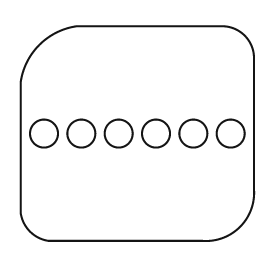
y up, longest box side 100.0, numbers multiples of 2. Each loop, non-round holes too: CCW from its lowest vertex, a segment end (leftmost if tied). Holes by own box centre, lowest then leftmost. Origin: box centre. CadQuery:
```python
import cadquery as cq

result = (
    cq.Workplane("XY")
    .moveTo(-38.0, -46.0)
    .lineTo(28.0, -46.0)
    .threePointArc((44.0, -40.0), (50.0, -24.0))
    .lineTo(50.0, 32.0)
    .threePointArc((46.0, 42.0), (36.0, 46.0))
    .lineTo(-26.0, 46.0)
    .threePointArc((-42.0, 38.0), (-50.0, 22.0))
    .lineTo(-50.0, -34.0)
    .threePointArc((-46.0, -42.0), (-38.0, -46.0))
    .close()
    .moveTo(-40.0, 0.0)
    .circle(6.0)
    .moveTo(-24.0, 0.0)
    .circle(6.0)
    .moveTo(-8.0, 0.0)
    .circle(6.0)
    .moveTo(8.0, 0.0)
    .circle(6.0)
    .moveTo(24.0, 0.0)
    .circle(6.0)
    .moveTo(40.0, 0.0)
    .circle(6.0)
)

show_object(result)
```